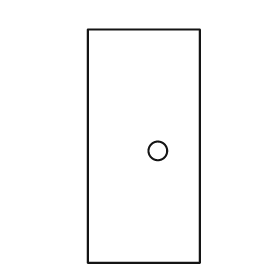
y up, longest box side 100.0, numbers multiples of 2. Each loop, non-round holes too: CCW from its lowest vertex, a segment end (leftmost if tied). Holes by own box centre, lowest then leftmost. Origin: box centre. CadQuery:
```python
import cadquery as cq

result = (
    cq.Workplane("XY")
    .moveTo(-24.0, -50.0)
    .lineTo(24.0, -50.0)
    .lineTo(24.0, 50.0)
    .lineTo(-24.0, 50.0)
    .close()
    .moveTo(6.0, -2.0)
    .circle(4.0)
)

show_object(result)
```